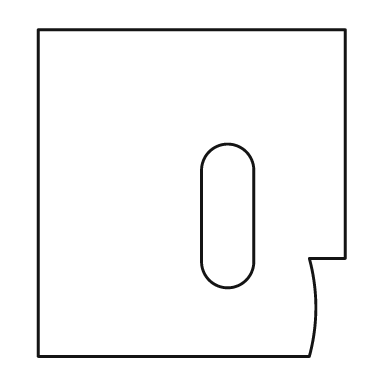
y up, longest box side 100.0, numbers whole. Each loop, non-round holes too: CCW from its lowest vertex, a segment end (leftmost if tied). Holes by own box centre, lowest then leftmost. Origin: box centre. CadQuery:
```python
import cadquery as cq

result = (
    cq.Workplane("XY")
    .moveTo(-47.0, -50.0)
    .lineTo(36.0, -50.0)
    .threePointArc((38.0, -35.0), (36.0, -20.0))
    .lineTo(47.0, -20.0)
    .lineTo(47.0, 50.0)
    .lineTo(-47.0, 50.0)
    .close()
    .moveTo(3.0, -21.0)
    .threePointArc((11.0, -29.0), (19.0, -21.0))
    .lineTo(19.0, 7.0)
    .threePointArc((11.0, 15.0), (3.0, 7.0))
    .close()
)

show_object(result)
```